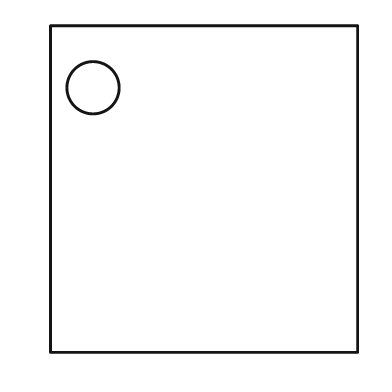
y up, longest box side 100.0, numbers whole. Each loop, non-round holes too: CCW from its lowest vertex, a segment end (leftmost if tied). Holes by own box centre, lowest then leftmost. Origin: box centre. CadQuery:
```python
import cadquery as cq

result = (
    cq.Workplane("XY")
    .moveTo(-47.0, -50.0)
    .lineTo(47.0, -50.0)
    .lineTo(47.0, 50.0)
    .lineTo(-47.0, 50.0)
    .close()
    .moveTo(-34.0, 31.0)
    .circle(8.0)
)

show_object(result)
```